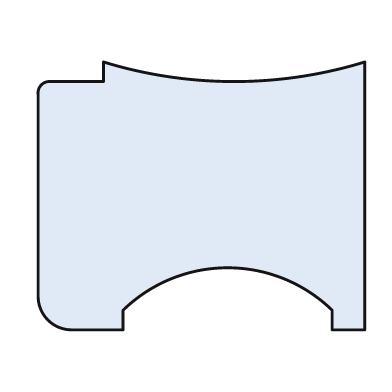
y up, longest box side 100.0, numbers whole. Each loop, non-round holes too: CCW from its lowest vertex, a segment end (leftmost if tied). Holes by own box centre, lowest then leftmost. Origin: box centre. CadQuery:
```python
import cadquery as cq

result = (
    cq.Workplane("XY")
    .moveTo(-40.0, -41.0)
    .lineTo(-24.0, -41.0)
    .lineTo(-24.0, -35.0)
    .threePointArc((8.0, -22.0), (40.0, -35.0))
    .lineTo(40.0, -41.0)
    .lineTo(50.0, -41.0)
    .lineTo(50.0, 41.0)
    .threePointArc((10.0, 35.0), (-30.0, 41.0))
    .lineTo(-30.0, 35.0)
    .lineTo(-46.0, 35.0)
    .threePointArc((-49.0, 34.0), (-50.0, 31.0))
    .lineTo(-50.0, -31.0)
    .threePointArc((-47.0, -38.0), (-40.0, -41.0))
    .close()
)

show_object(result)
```